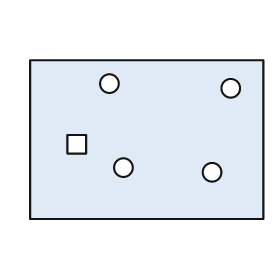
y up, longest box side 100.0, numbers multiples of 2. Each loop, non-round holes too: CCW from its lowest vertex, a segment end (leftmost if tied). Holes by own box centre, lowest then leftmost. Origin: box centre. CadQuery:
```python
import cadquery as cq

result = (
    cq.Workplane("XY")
    .moveTo(-50.0, -34.0)
    .lineTo(50.0, -34.0)
    .lineTo(50.0, 34.0)
    .lineTo(-50.0, 34.0)
    .close()
    .moveTo(28.0, -14.0)
    .circle(4.0)
    .moveTo(-10.0, -12.0)
    .circle(4.0)
    .moveTo(-34.0, -6.0)
    .lineTo(-26.0, -6.0)
    .lineTo(-26.0, 2.0)
    .lineTo(-34.0, 2.0)
    .close()
    .moveTo(36.0, 22.0)
    .circle(4.0)
    .moveTo(-16.0, 24.0)
    .circle(4.0)
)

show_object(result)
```